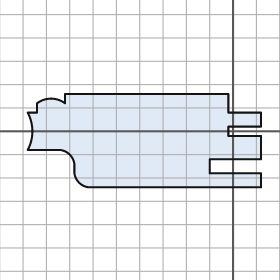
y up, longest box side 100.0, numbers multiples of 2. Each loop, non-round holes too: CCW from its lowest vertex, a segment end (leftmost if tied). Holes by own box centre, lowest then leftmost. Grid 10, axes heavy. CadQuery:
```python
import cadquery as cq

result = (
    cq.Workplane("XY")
    .moveTo(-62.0, -24.0)
    .lineTo(12.0, -24.0)
    .lineTo(12.0, -18.0)
    .lineTo(-10.0, -18.0)
    .lineTo(-10.0, -12.0)
    .lineTo(12.0, -12.0)
    .lineTo(12.0, -2.0)
    .lineTo(-2.0, -2.0)
    .lineTo(-2.0, 2.0)
    .lineTo(12.0, 2.0)
    .lineTo(12.0, 8.0)
    .lineTo(-2.0, 8.0)
    .lineTo(-2.0, 16.0)
    .lineTo(-72.0, 16.0)
    .lineTo(-72.0, 12.0)
    .threePointArc((-78.0, 14.0), (-84.0, 12.0))
    .lineTo(-84.0, 8.0)
    .lineTo(-88.0, 8.0)
    .threePointArc((-86.0, 0.0), (-88.0, -8.0))
    .lineTo(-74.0, -8.0)
    .threePointArc((-70.0, -10.0), (-68.0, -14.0))
    .lineTo(-68.0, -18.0)
    .threePointArc((-66.0, -22.0), (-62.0, -24.0))
    .close()
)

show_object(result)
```